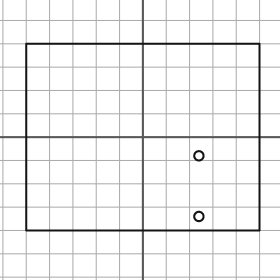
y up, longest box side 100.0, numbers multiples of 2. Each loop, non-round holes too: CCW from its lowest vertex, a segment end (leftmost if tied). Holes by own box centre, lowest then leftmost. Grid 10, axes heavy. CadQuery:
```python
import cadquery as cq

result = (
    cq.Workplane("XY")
    .moveTo(-50.0, -40.0)
    .lineTo(50.0, -40.0)
    .lineTo(50.0, 40.0)
    .lineTo(-50.0, 40.0)
    .close()
    .moveTo(24.0, -34.0)
    .circle(2.0)
    .moveTo(24.0, -8.0)
    .circle(2.0)
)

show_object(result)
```